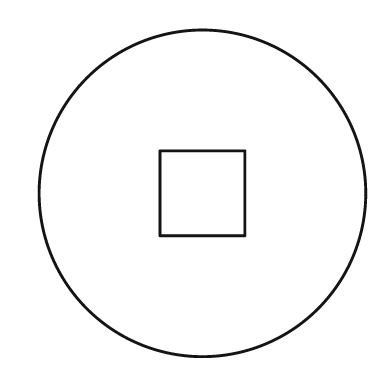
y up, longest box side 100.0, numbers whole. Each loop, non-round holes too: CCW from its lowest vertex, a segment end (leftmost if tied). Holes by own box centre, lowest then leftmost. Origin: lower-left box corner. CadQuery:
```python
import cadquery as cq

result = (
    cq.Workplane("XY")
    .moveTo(50.0, 50.0)
    .circle(50.0)
    .moveTo(37.0, 37.0)
    .lineTo(63.0, 37.0)
    .lineTo(63.0, 63.0)
    .lineTo(37.0, 63.0)
    .close()
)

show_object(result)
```